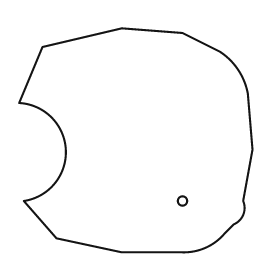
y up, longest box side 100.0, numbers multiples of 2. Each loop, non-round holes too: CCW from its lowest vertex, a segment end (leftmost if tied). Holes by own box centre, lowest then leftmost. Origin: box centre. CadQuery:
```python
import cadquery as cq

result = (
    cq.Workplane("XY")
    .moveTo(-6.0, -48.0)
    .lineTo(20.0, -48.0)
    .threePointArc((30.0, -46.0), (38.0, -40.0))
    .lineTo(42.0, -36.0)
    .threePointArc((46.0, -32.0), (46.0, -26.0))
    .lineTo(50.0, -4.0)
    .lineTo(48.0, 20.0)
    .threePointArc((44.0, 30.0), (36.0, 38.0))
    .lineTo(20.0, 46.0)
    .lineTo(-6.0, 48.0)
    .lineTo(-40.0, 40.0)
    .lineTo(-50.0, 16.0)
    .threePointArc((-30.0, -4.0), (-48.0, -26.0))
    .lineTo(-34.0, -42.0)
    .close()
    .moveTo(20.0, -26.0)
    .circle(2.0)
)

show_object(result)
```